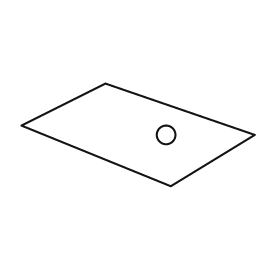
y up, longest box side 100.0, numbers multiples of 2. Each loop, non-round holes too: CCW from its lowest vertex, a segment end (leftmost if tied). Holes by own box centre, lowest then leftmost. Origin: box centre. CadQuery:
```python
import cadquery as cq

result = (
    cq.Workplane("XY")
    .moveTo(14.0, -22.0)
    .lineTo(50.0, 0.0)
    .lineTo(-14.0, 22.0)
    .lineTo(-50.0, 4.0)
    .close()
    .moveTo(12.0, 0.0)
    .circle(4.0)
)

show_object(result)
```